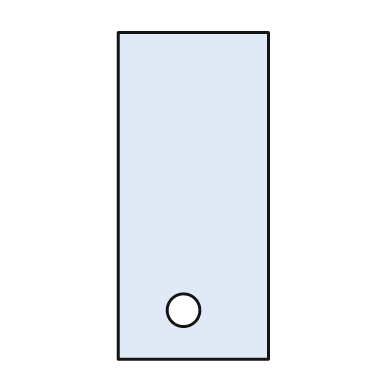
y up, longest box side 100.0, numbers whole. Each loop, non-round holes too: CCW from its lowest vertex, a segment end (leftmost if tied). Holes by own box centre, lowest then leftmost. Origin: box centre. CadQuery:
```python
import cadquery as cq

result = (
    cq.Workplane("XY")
    .moveTo(-23.0, -50.0)
    .lineTo(23.0, -50.0)
    .lineTo(23.0, 50.0)
    .lineTo(-23.0, 50.0)
    .close()
    .moveTo(-3.0, -35.0)
    .circle(5.0)
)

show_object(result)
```